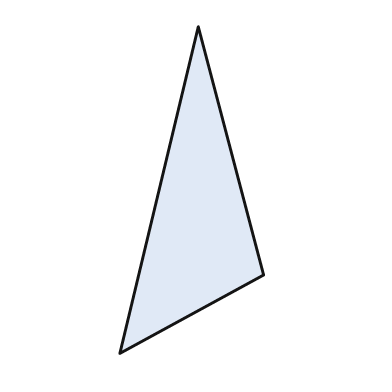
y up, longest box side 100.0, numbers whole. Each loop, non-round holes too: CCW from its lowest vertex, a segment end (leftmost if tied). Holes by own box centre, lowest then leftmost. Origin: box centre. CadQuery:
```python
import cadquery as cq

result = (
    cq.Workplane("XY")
    .moveTo(-22.0, -50.0)
    .lineTo(22.0, -26.0)
    .lineTo(2.0, 50.0)
    .close()
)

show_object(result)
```